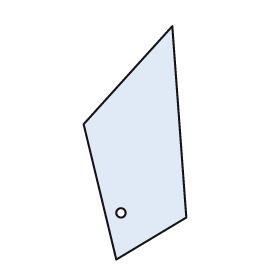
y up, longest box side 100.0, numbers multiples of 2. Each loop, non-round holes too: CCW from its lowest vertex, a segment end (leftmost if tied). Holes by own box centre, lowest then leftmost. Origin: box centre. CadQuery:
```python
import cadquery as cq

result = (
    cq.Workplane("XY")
    .moveTo(-8.0, -50.0)
    .lineTo(22.0, -32.0)
    .lineTo(16.0, 50.0)
    .lineTo(-22.0, 8.0)
    .close()
    .moveTo(-6.0, -30.0)
    .circle(2.0)
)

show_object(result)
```